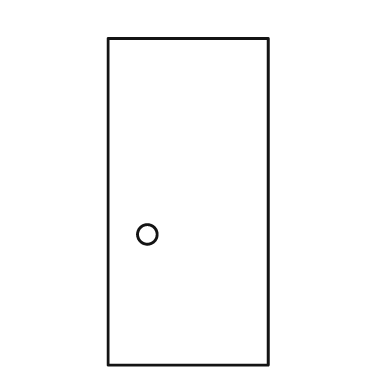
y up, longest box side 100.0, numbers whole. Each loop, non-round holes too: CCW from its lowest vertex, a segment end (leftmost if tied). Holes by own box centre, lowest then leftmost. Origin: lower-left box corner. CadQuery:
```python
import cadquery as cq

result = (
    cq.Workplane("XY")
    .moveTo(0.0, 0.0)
    .lineTo(49.0, 0.0)
    .lineTo(49.0, 100.0)
    .lineTo(0.0, 100.0)
    .close()
    .moveTo(12.0, 40.0)
    .circle(3.0)
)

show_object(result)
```